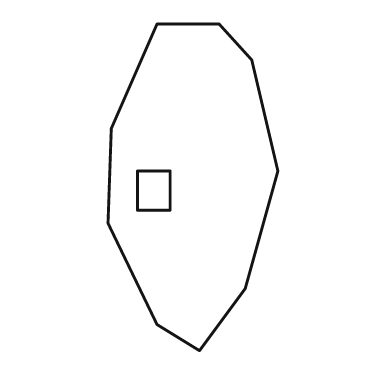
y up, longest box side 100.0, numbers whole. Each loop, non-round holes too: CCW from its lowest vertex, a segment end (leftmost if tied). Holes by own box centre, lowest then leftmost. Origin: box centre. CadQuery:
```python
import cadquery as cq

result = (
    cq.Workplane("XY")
    .moveTo(2.0, -50.0)
    .lineTo(16.0, -31.0)
    .lineTo(26.0, 5.0)
    .lineTo(18.0, 39.0)
    .lineTo(8.0, 50.0)
    .lineTo(-11.0, 50.0)
    .lineTo(-25.0, 18.0)
    .lineTo(-26.0, -11.0)
    .lineTo(-11.0, -42.0)
    .close()
    .moveTo(-17.0, -7.0)
    .lineTo(-7.0, -7.0)
    .lineTo(-7.0, 5.0)
    .lineTo(-17.0, 5.0)
    .close()
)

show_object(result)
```